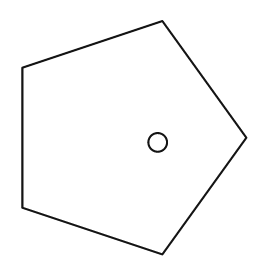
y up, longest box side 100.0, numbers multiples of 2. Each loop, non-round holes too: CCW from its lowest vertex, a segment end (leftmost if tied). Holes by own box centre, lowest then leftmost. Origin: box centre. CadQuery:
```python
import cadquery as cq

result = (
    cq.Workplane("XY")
    .moveTo(12.0, -50.0)
    .lineTo(48.0, 0.0)
    .lineTo(12.0, 50.0)
    .lineTo(-48.0, 30.0)
    .lineTo(-48.0, -30.0)
    .close()
    .moveTo(10.0, -2.0)
    .circle(4.0)
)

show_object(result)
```